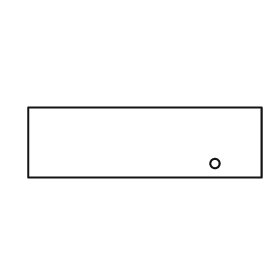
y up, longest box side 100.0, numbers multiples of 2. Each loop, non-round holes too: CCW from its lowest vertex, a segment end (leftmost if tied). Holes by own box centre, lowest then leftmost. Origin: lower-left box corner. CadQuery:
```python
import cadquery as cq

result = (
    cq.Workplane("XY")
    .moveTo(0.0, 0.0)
    .lineTo(100.0, 0.0)
    .lineTo(100.0, 30.0)
    .lineTo(0.0, 30.0)
    .close()
    .moveTo(80.0, 6.0)
    .circle(2.0)
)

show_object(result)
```